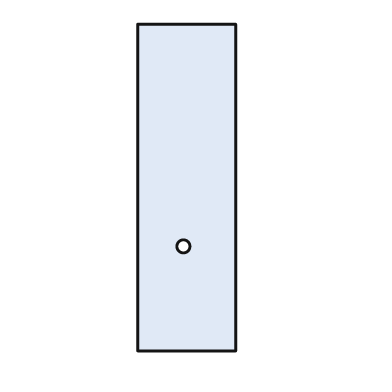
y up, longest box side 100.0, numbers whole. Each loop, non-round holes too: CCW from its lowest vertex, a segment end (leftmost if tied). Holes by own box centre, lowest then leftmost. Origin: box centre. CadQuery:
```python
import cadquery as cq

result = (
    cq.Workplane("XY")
    .moveTo(-15.0, -50.0)
    .lineTo(15.0, -50.0)
    .lineTo(15.0, 50.0)
    .lineTo(-15.0, 50.0)
    .close()
    .moveTo(-1.0, -18.0)
    .circle(2.0)
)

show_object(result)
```